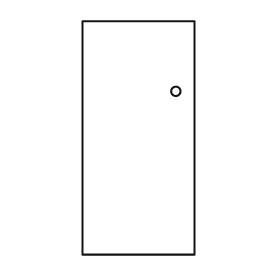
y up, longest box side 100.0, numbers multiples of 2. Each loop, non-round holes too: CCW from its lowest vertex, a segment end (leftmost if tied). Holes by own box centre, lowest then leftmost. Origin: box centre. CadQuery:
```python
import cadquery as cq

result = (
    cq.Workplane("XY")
    .moveTo(-24.0, -50.0)
    .lineTo(24.0, -50.0)
    .lineTo(24.0, 50.0)
    .lineTo(-24.0, 50.0)
    .close()
    .moveTo(16.0, 20.0)
    .circle(2.0)
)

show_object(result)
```